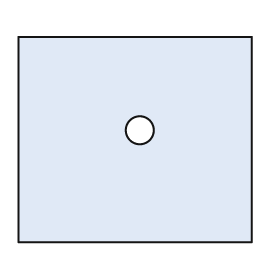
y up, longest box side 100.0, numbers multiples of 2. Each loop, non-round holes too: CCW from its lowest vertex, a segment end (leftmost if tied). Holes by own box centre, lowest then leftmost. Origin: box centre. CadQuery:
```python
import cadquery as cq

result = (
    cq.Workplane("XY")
    .moveTo(-50.0, -44.0)
    .lineTo(50.0, -44.0)
    .lineTo(50.0, 44.0)
    .lineTo(-50.0, 44.0)
    .close()
    .moveTo(2.0, 4.0)
    .circle(6.0)
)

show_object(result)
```